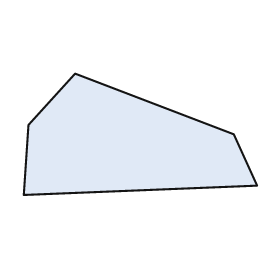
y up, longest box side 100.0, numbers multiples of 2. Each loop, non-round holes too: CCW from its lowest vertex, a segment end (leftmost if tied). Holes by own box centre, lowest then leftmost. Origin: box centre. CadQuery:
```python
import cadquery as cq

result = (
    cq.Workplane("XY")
    .moveTo(-50.0, -26.0)
    .lineTo(50.0, -22.0)
    .lineTo(40.0, 0.0)
    .lineTo(-28.0, 26.0)
    .lineTo(-48.0, 4.0)
    .close()
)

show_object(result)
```